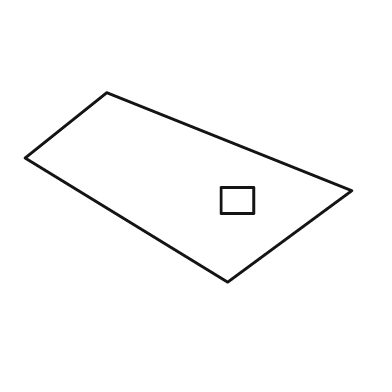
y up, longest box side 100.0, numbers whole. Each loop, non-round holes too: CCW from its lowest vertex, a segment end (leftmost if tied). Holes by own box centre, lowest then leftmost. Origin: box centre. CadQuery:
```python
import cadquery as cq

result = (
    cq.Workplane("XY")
    .moveTo(12.0, -29.0)
    .lineTo(50.0, -1.0)
    .lineTo(-25.0, 29.0)
    .lineTo(-50.0, 9.0)
    .close()
    .moveTo(10.0, -8.0)
    .lineTo(20.0, -8.0)
    .lineTo(20.0, 0.0)
    .lineTo(10.0, 0.0)
    .close()
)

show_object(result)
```